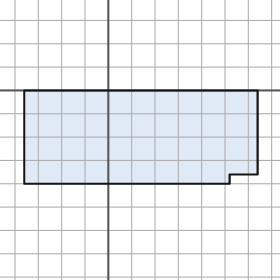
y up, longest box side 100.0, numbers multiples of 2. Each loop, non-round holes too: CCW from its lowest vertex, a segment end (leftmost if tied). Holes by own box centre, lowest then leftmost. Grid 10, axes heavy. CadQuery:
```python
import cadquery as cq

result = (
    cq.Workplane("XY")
    .moveTo(-36.0, -40.0)
    .lineTo(52.0, -40.0)
    .lineTo(52.0, -36.0)
    .lineTo(64.0, -36.0)
    .lineTo(64.0, 0.0)
    .lineTo(-36.0, 0.0)
    .close()
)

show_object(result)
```